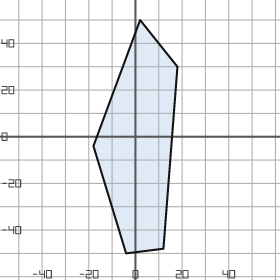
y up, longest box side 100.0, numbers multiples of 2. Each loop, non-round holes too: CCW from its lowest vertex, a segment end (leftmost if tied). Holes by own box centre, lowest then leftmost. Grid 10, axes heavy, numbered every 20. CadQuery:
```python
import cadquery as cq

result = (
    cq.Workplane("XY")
    .moveTo(-4.0, -50.0)
    .lineTo(12.0, -48.0)
    .lineTo(18.0, 30.0)
    .lineTo(2.0, 50.0)
    .lineTo(-18.0, -4.0)
    .close()
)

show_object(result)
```